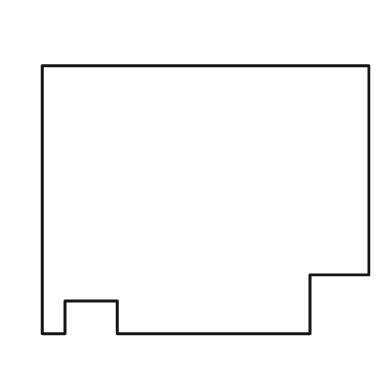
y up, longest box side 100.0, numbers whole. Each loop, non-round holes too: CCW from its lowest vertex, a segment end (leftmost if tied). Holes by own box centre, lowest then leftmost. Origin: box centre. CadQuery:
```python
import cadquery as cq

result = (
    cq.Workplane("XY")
    .moveTo(-50.0, -41.0)
    .lineTo(-43.0, -41.0)
    .lineTo(-43.0, -31.0)
    .lineTo(-27.0, -31.0)
    .lineTo(-27.0, -41.0)
    .lineTo(32.0, -41.0)
    .lineTo(32.0, -23.0)
    .lineTo(50.0, -23.0)
    .lineTo(50.0, 41.0)
    .lineTo(-50.0, 41.0)
    .close()
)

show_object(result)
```